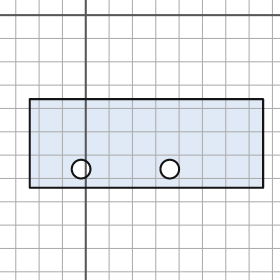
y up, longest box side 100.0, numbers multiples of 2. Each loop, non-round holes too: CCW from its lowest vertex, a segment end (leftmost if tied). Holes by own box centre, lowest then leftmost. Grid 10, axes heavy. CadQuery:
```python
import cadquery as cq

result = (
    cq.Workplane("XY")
    .moveTo(-24.0, -74.0)
    .lineTo(76.0, -74.0)
    .lineTo(76.0, -36.0)
    .lineTo(-24.0, -36.0)
    .close()
    .moveTo(-2.0, -66.0)
    .circle(4.0)
    .moveTo(36.0, -66.0)
    .circle(4.0)
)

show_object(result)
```